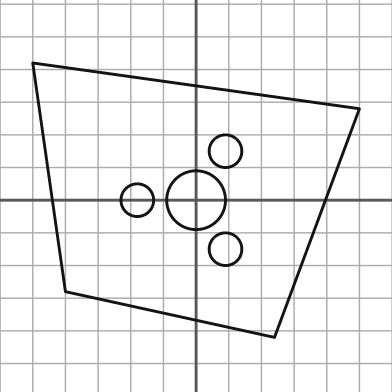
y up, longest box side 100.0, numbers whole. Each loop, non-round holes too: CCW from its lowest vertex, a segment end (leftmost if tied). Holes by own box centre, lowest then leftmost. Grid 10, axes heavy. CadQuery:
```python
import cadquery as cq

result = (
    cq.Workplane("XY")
    .moveTo(24.0, -42.0)
    .lineTo(50.0, 28.0)
    .lineTo(-50.0, 42.0)
    .lineTo(-40.0, -28.0)
    .close()
    .moveTo(9.0, -15.0)
    .circle(5.0)
    .moveTo(-18.0, 0.0)
    .circle(5.0)
    .moveTo(0.0, 0.0)
    .circle(9.0)
    .moveTo(9.0, 15.0)
    .circle(5.0)
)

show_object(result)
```